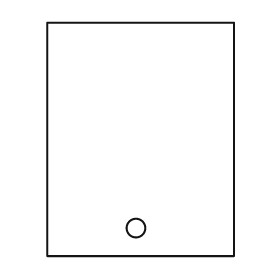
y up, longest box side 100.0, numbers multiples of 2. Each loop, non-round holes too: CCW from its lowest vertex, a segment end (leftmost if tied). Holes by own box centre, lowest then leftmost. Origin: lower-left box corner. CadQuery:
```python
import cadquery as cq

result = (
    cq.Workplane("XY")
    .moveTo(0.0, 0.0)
    .lineTo(80.0, 0.0)
    .lineTo(80.0, 100.0)
    .lineTo(0.0, 100.0)
    .close()
    .moveTo(38.0, 12.0)
    .circle(4.0)
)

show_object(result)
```